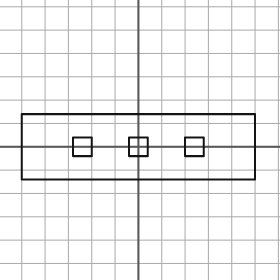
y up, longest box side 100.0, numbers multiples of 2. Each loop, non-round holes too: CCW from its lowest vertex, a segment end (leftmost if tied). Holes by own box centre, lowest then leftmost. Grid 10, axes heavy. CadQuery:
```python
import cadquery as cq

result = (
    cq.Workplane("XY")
    .moveTo(-50.0, -14.0)
    .lineTo(50.0, -14.0)
    .lineTo(50.0, 14.0)
    .lineTo(-50.0, 14.0)
    .close()
    .moveTo(-28.0, -4.0)
    .lineTo(-20.0, -4.0)
    .lineTo(-20.0, 4.0)
    .lineTo(-28.0, 4.0)
    .close()
    .moveTo(-4.0, -4.0)
    .lineTo(4.0, -4.0)
    .lineTo(4.0, 4.0)
    .lineTo(-4.0, 4.0)
    .close()
    .moveTo(20.0, -4.0)
    .lineTo(28.0, -4.0)
    .lineTo(28.0, 4.0)
    .lineTo(20.0, 4.0)
    .close()
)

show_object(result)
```